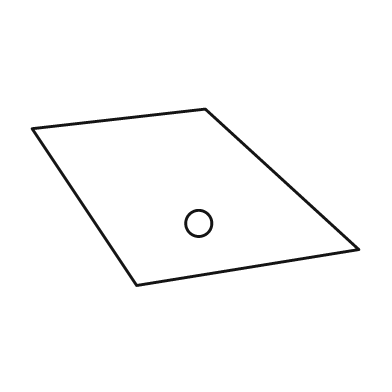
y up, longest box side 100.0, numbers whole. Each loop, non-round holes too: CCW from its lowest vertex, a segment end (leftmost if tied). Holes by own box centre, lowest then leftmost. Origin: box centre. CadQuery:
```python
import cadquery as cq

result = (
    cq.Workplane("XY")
    .moveTo(-18.0, -27.0)
    .lineTo(50.0, -16.0)
    .lineTo(3.0, 27.0)
    .lineTo(-50.0, 21.0)
    .close()
    .moveTo(1.0, -8.0)
    .circle(4.0)
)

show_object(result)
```